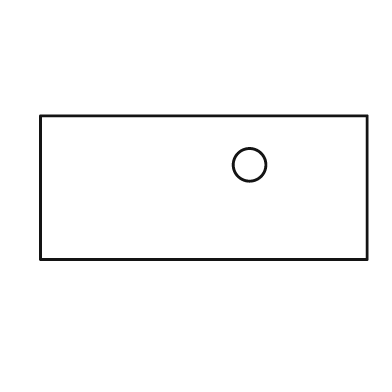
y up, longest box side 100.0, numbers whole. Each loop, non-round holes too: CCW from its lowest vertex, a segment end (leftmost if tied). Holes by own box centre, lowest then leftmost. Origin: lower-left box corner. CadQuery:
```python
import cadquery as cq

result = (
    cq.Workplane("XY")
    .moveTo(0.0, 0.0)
    .lineTo(100.0, 0.0)
    .lineTo(100.0, 44.0)
    .lineTo(0.0, 44.0)
    .close()
    .moveTo(64.0, 29.0)
    .circle(5.0)
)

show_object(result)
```